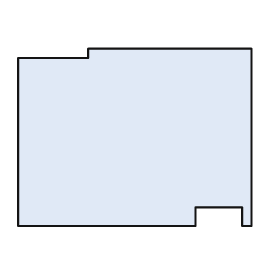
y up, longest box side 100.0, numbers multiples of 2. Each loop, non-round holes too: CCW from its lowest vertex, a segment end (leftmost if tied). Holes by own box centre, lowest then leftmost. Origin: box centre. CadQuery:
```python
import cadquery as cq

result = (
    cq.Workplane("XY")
    .moveTo(-50.0, -38.0)
    .lineTo(26.0, -38.0)
    .lineTo(26.0, -30.0)
    .lineTo(46.0, -30.0)
    .lineTo(46.0, -38.0)
    .lineTo(50.0, -38.0)
    .lineTo(50.0, 38.0)
    .lineTo(-20.0, 38.0)
    .lineTo(-20.0, 34.0)
    .lineTo(-50.0, 34.0)
    .close()
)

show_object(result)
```